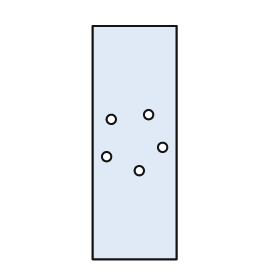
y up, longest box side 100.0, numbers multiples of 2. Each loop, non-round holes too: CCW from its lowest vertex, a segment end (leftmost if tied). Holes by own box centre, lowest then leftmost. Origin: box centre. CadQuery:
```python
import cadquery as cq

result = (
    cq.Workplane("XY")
    .moveTo(-18.0, -50.0)
    .lineTo(18.0, -50.0)
    .lineTo(18.0, 50.0)
    .lineTo(-18.0, 50.0)
    .close()
    .moveTo(2.0, -12.0)
    .circle(2.0)
    .moveTo(-12.0, -6.0)
    .circle(2.0)
    .moveTo(12.0, -2.0)
    .circle(2.0)
    .moveTo(-10.0, 10.0)
    .circle(2.0)
    .moveTo(6.0, 12.0)
    .circle(2.0)
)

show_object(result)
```